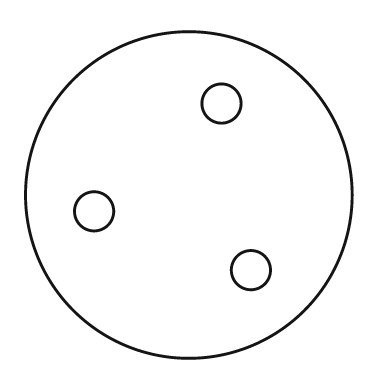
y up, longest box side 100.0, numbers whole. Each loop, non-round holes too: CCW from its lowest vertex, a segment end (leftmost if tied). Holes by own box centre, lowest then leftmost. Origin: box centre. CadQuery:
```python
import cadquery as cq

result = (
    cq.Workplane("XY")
    .moveTo(0.0, 0.0)
    .circle(50.0)
    .moveTo(19.0, -23.0)
    .circle(6.0)
    .moveTo(-29.0, -5.0)
    .circle(6.0)
    .moveTo(10.0, 28.0)
    .circle(6.0)
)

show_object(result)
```